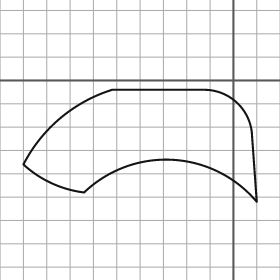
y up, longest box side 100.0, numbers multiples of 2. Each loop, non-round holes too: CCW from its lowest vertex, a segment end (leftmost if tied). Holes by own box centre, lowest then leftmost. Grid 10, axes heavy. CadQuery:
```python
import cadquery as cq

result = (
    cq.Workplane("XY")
    .moveTo(10.0, -52.0)
    .lineTo(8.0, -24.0)
    .threePointArc((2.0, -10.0), (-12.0, -4.0))
    .lineTo(-52.0, -4.0)
    .threePointArc((-74.0, -16.0), (-90.0, -36.0))
    .threePointArc((-78.0, -44.0), (-64.0, -48.0))
    .threePointArc((-26.0, -34.0), (10.0, -52.0))
    .close()
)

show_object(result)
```